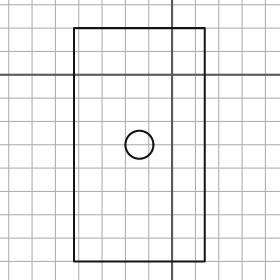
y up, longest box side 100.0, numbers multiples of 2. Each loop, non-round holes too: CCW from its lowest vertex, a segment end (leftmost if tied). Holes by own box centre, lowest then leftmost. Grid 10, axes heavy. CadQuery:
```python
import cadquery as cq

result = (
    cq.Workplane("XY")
    .moveTo(-42.0, -80.0)
    .lineTo(14.0, -80.0)
    .lineTo(14.0, 20.0)
    .lineTo(-42.0, 20.0)
    .close()
    .moveTo(-14.0, -30.0)
    .circle(6.0)
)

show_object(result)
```